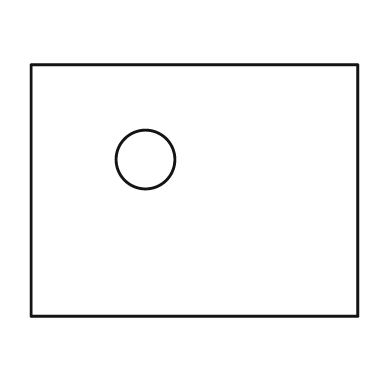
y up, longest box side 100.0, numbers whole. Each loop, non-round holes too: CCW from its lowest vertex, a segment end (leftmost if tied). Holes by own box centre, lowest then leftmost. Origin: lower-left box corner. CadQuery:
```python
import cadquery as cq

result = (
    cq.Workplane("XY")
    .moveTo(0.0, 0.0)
    .lineTo(100.0, 0.0)
    .lineTo(100.0, 77.0)
    .lineTo(0.0, 77.0)
    .close()
    .moveTo(35.0, 48.0)
    .circle(9.0)
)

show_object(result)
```